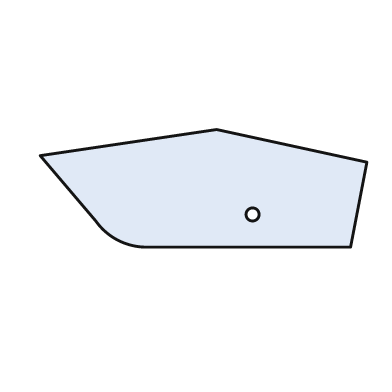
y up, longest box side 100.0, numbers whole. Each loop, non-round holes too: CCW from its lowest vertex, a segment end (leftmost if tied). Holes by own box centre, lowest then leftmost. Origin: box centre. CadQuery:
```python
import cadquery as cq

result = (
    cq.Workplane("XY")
    .moveTo(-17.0, -18.0)
    .lineTo(45.0, -18.0)
    .lineTo(50.0, 8.0)
    .lineTo(4.0, 18.0)
    .lineTo(-50.0, 10.0)
    .lineTo(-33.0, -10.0)
    .threePointArc((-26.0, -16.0), (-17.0, -18.0))
    .close()
    .moveTo(15.0, -8.0)
    .circle(2.0)
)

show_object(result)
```